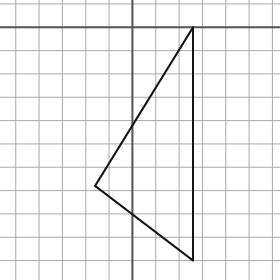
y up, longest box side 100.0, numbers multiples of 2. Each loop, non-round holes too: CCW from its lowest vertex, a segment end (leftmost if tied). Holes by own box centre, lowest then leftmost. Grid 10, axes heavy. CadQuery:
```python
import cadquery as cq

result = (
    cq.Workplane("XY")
    .moveTo(26.0, -100.0)
    .lineTo(26.0, 0.0)
    .lineTo(-16.0, -68.0)
    .close()
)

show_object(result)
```